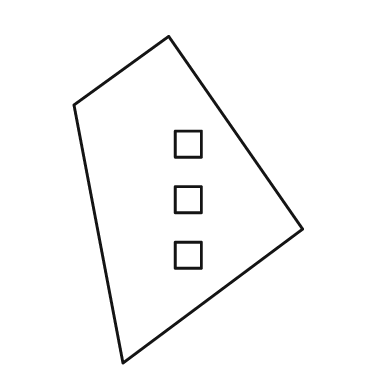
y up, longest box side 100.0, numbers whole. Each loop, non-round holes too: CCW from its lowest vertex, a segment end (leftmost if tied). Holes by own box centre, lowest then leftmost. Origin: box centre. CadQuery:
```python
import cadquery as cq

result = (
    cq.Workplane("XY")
    .moveTo(-20.0, -50.0)
    .lineTo(35.0, -9.0)
    .lineTo(-6.0, 50.0)
    .lineTo(-35.0, 29.0)
    .close()
    .moveTo(-4.0, -21.0)
    .lineTo(4.0, -21.0)
    .lineTo(4.0, -13.0)
    .lineTo(-4.0, -13.0)
    .close()
    .moveTo(-4.0, -4.0)
    .lineTo(4.0, -4.0)
    .lineTo(4.0, 4.0)
    .lineTo(-4.0, 4.0)
    .close()
    .moveTo(-4.0, 13.0)
    .lineTo(4.0, 13.0)
    .lineTo(4.0, 21.0)
    .lineTo(-4.0, 21.0)
    .close()
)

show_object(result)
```